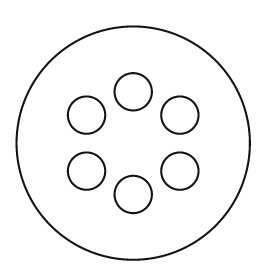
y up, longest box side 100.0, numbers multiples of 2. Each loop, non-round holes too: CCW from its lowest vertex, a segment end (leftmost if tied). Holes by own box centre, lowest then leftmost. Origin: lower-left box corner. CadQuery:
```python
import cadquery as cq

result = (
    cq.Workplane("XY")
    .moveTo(50.0, 50.0)
    .circle(50.0)
    .moveTo(50.0, 28.0)
    .circle(8.0)
    .moveTo(30.0, 38.0)
    .circle(8.0)
    .moveTo(70.0, 38.0)
    .circle(8.0)
    .moveTo(30.0, 62.0)
    .circle(8.0)
    .moveTo(70.0, 62.0)
    .circle(8.0)
    .moveTo(50.0, 72.0)
    .circle(8.0)
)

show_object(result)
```